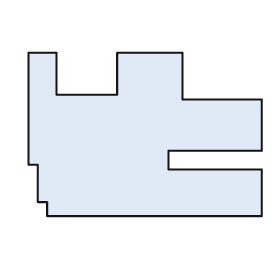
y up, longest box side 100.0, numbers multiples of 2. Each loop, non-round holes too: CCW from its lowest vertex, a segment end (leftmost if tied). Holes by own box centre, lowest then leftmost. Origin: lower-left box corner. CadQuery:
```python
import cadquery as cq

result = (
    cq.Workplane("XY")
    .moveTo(8.0, 0.0)
    .lineTo(100.0, 0.0)
    .lineTo(100.0, 20.0)
    .lineTo(60.0, 20.0)
    .lineTo(60.0, 28.0)
    .lineTo(100.0, 28.0)
    .lineTo(100.0, 50.0)
    .lineTo(66.0, 50.0)
    .lineTo(66.0, 70.0)
    .lineTo(38.0, 70.0)
    .lineTo(38.0, 52.0)
    .lineTo(12.0, 52.0)
    .lineTo(12.0, 70.0)
    .lineTo(0.0, 70.0)
    .lineTo(0.0, 22.0)
    .lineTo(4.0, 22.0)
    .lineTo(4.0, 6.0)
    .lineTo(8.0, 6.0)
    .close()
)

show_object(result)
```